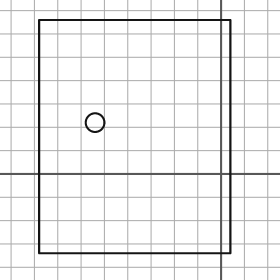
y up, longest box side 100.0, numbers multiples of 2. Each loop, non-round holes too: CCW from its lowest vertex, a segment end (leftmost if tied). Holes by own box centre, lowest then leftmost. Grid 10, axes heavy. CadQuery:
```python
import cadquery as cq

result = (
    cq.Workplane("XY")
    .moveTo(-78.0, -34.0)
    .lineTo(4.0, -34.0)
    .lineTo(4.0, 66.0)
    .lineTo(-78.0, 66.0)
    .close()
    .moveTo(-54.0, 22.0)
    .circle(4.0)
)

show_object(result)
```